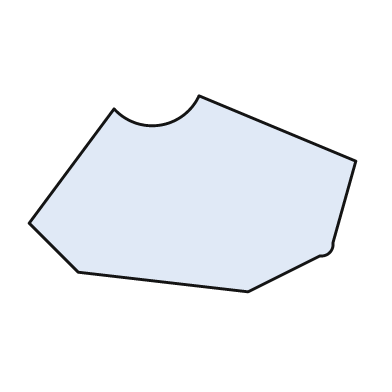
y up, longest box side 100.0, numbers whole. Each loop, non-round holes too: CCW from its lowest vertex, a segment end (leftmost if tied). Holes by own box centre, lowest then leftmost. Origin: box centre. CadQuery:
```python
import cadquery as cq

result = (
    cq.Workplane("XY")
    .moveTo(17.0, -30.0)
    .lineTo(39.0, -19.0)
    .threePointArc((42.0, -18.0), (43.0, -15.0))
    .lineTo(50.0, 10.0)
    .lineTo(2.0, 30.0)
    .threePointArc((-10.0, 21.0), (-24.0, 26.0))
    .lineTo(-50.0, -9.0)
    .lineTo(-35.0, -24.0)
    .close()
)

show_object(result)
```